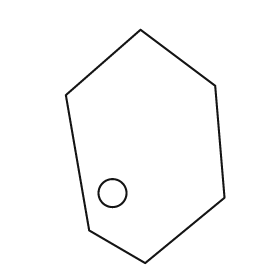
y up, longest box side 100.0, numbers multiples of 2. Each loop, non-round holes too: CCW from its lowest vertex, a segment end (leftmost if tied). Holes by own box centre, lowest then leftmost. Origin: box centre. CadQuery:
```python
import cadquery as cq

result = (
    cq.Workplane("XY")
    .moveTo(0.0, -50.0)
    .lineTo(34.0, -22.0)
    .lineTo(30.0, 26.0)
    .lineTo(-2.0, 50.0)
    .lineTo(-34.0, 22.0)
    .lineTo(-24.0, -36.0)
    .close()
    .moveTo(-14.0, -20.0)
    .circle(6.0)
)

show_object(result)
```